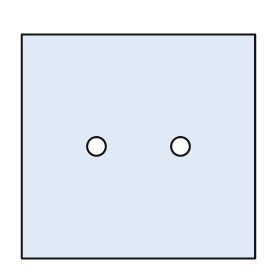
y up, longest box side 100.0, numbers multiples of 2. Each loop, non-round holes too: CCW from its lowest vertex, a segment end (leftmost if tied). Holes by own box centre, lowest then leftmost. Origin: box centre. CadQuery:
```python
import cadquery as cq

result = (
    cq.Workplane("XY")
    .moveTo(-50.0, -48.0)
    .lineTo(50.0, -48.0)
    .lineTo(50.0, 48.0)
    .lineTo(-50.0, 48.0)
    .close()
    .moveTo(-18.0, 0.0)
    .circle(4.0)
    .moveTo(18.0, 0.0)
    .circle(4.0)
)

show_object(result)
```